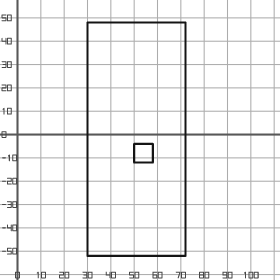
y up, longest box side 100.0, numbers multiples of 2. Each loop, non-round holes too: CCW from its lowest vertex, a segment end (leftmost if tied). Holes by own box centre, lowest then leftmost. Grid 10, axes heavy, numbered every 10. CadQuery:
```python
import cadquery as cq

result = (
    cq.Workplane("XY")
    .moveTo(30.0, -52.0)
    .lineTo(72.0, -52.0)
    .lineTo(72.0, 48.0)
    .lineTo(30.0, 48.0)
    .close()
    .moveTo(50.0, -12.0)
    .lineTo(58.0, -12.0)
    .lineTo(58.0, -4.0)
    .lineTo(50.0, -4.0)
    .close()
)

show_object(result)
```